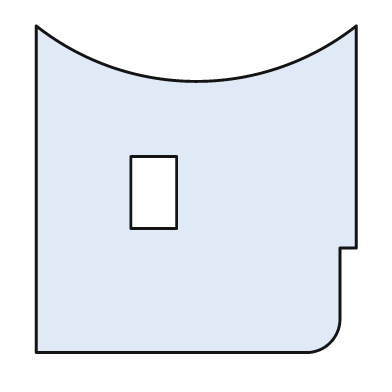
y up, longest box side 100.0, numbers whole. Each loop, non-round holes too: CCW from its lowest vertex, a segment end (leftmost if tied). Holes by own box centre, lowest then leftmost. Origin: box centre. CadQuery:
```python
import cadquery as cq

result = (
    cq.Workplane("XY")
    .moveTo(-49.0, -50.0)
    .lineTo(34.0, -50.0)
    .threePointArc((41.0, -47.0), (44.0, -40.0))
    .lineTo(44.0, -18.0)
    .lineTo(49.0, -18.0)
    .lineTo(49.0, 50.0)
    .threePointArc((0.0, 33.0), (-49.0, 50.0))
    .close()
    .moveTo(-20.0, -12.0)
    .lineTo(-6.0, -12.0)
    .lineTo(-6.0, 10.0)
    .lineTo(-20.0, 10.0)
    .close()
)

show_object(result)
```